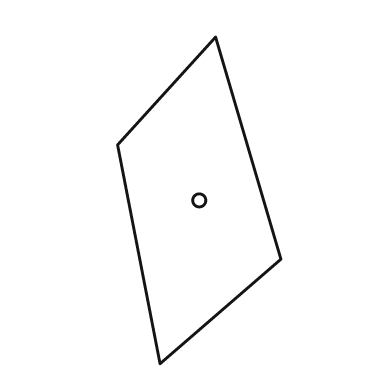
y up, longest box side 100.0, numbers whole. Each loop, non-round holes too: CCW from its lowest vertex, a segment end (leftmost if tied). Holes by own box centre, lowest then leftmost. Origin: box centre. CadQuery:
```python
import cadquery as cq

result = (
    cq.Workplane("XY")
    .moveTo(-12.0, -50.0)
    .lineTo(25.0, -18.0)
    .lineTo(5.0, 50.0)
    .lineTo(-25.0, 17.0)
    .close()
    .moveTo(0.0, 0.0)
    .circle(2.0)
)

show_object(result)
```